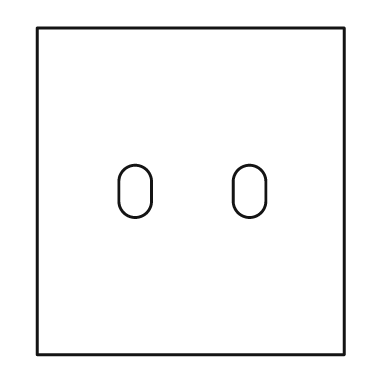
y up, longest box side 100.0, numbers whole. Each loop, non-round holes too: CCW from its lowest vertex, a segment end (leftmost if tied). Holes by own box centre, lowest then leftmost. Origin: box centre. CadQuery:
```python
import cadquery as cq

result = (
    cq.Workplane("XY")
    .moveTo(-47.0, -50.0)
    .lineTo(47.0, -50.0)
    .lineTo(47.0, 50.0)
    .lineTo(-47.0, 50.0)
    .close()
    .moveTo(-22.0, -3.0)
    .threePointArc((-17.0, -8.0), (-12.0, -3.0))
    .lineTo(-12.0, 3.0)
    .threePointArc((-17.0, 8.0), (-22.0, 3.0))
    .close()
    .moveTo(13.0, -3.0)
    .threePointArc((18.0, -8.0), (23.0, -3.0))
    .lineTo(23.0, 3.0)
    .threePointArc((18.0, 8.0), (13.0, 3.0))
    .close()
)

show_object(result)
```